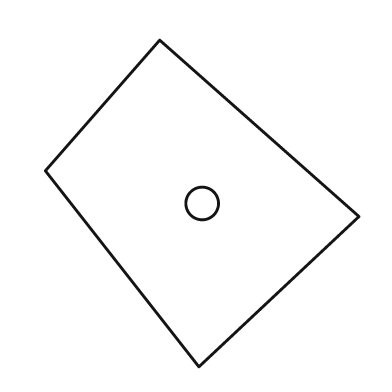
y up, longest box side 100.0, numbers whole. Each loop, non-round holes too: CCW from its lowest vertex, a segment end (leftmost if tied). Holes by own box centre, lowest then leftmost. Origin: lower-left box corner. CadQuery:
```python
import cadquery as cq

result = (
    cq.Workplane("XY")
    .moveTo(47.0, 0.0)
    .lineTo(96.0, 46.0)
    .lineTo(35.0, 100.0)
    .lineTo(0.0, 60.0)
    .close()
    .moveTo(48.0, 50.0)
    .circle(5.0)
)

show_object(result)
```